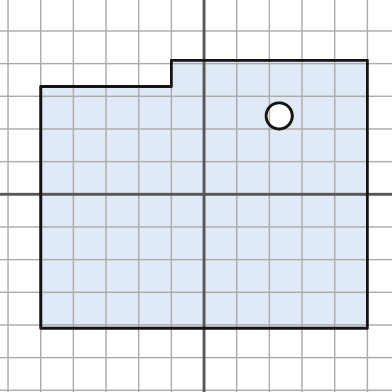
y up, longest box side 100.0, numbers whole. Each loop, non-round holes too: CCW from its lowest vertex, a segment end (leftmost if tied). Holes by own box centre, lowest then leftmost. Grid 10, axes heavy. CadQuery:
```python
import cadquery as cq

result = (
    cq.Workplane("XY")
    .moveTo(-50.0, -41.0)
    .lineTo(50.0, -41.0)
    .lineTo(50.0, 41.0)
    .lineTo(-10.0, 41.0)
    .lineTo(-10.0, 33.0)
    .lineTo(-50.0, 33.0)
    .close()
    .moveTo(23.0, 24.0)
    .circle(4.0)
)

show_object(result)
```